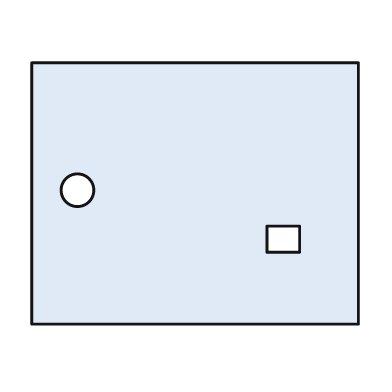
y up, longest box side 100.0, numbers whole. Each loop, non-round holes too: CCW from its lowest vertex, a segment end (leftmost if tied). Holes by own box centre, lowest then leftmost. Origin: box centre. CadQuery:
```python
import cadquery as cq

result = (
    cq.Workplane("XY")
    .moveTo(-50.0, -40.0)
    .lineTo(50.0, -40.0)
    .lineTo(50.0, 40.0)
    .lineTo(-50.0, 40.0)
    .close()
    .moveTo(22.0, -18.0)
    .lineTo(32.0, -18.0)
    .lineTo(32.0, -10.0)
    .lineTo(22.0, -10.0)
    .close()
    .moveTo(-36.0, 1.0)
    .circle(5.0)
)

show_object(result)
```